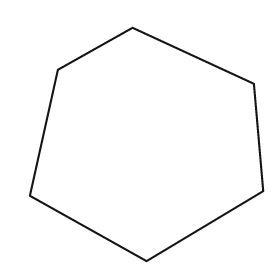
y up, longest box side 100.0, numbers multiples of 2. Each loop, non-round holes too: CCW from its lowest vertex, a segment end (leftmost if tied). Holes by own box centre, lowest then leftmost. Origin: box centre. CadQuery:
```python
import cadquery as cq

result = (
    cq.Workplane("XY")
    .moveTo(0.0, -50.0)
    .lineTo(50.0, -20.0)
    .lineTo(46.0, 26.0)
    .lineTo(-6.0, 50.0)
    .lineTo(-38.0, 32.0)
    .lineTo(-50.0, -22.0)
    .close()
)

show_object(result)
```